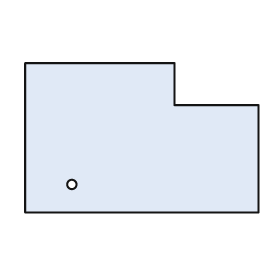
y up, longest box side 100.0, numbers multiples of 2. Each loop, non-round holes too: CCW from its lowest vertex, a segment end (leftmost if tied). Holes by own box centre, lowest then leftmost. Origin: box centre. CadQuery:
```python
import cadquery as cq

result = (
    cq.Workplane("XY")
    .moveTo(-50.0, -32.0)
    .lineTo(50.0, -32.0)
    .lineTo(50.0, 14.0)
    .lineTo(14.0, 14.0)
    .lineTo(14.0, 32.0)
    .lineTo(-50.0, 32.0)
    .close()
    .moveTo(-30.0, -20.0)
    .circle(2.0)
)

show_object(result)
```